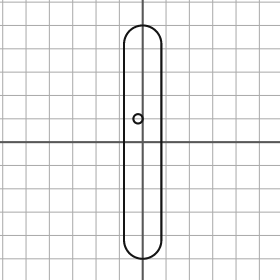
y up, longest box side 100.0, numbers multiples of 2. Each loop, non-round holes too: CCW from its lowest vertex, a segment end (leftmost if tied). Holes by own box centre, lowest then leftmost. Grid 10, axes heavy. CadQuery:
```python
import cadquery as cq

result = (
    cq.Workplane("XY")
    .moveTo(-8.0, -42.0)
    .threePointArc((0.0, -50.0), (8.0, -42.0))
    .lineTo(8.0, 42.0)
    .threePointArc((0.0, 50.0), (-8.0, 42.0))
    .close()
    .moveTo(-2.0, 10.0)
    .circle(2.0)
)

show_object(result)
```